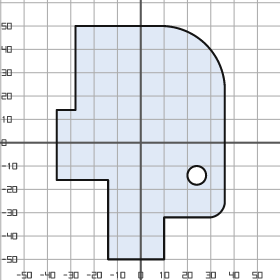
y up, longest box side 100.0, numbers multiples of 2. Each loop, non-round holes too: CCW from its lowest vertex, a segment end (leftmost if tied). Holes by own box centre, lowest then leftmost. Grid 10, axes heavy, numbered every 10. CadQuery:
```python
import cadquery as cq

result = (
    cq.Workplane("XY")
    .moveTo(-14.0, -50.0)
    .lineTo(10.0, -50.0)
    .lineTo(10.0, -32.0)
    .lineTo(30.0, -32.0)
    .threePointArc((34.0, -30.0), (36.0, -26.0))
    .lineTo(36.0, 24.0)
    .threePointArc((28.0, 42.0), (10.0, 50.0))
    .lineTo(-28.0, 50.0)
    .lineTo(-28.0, 14.0)
    .lineTo(-36.0, 14.0)
    .lineTo(-36.0, -16.0)
    .lineTo(-14.0, -16.0)
    .close()
    .moveTo(24.0, -14.0)
    .circle(4.0)
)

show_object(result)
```